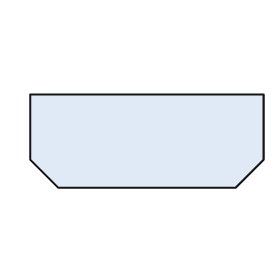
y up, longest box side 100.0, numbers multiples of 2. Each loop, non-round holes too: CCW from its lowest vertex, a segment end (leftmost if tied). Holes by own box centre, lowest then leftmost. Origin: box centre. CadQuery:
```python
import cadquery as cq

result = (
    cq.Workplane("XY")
    .moveTo(-38.0, -20.0)
    .lineTo(38.0, -20.0)
    .lineTo(50.0, -8.0)
    .lineTo(50.0, 20.0)
    .lineTo(-50.0, 20.0)
    .lineTo(-50.0, -8.0)
    .close()
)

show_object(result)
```